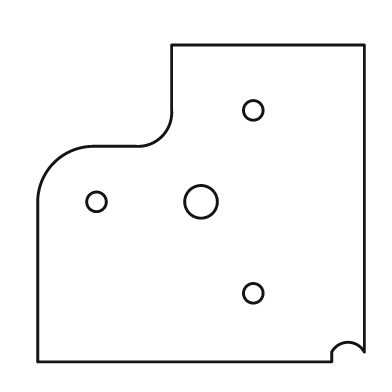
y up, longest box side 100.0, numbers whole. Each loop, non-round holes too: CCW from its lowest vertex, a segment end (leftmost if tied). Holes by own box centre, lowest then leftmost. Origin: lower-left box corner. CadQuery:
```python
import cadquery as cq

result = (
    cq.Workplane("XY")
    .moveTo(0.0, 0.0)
    .lineTo(90.0, 0.0)
    .lineTo(90.0, 3.0)
    .threePointArc((95.0, 6.0), (100.0, 3.0))
    .lineTo(100.0, 97.0)
    .lineTo(41.0, 97.0)
    .lineTo(41.0, 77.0)
    .threePointArc((38.0, 69.0), (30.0, 66.0))
    .lineTo(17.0, 66.0)
    .threePointArc((5.0, 61.0), (0.0, 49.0))
    .close()
    .moveTo(66.0, 21.0)
    .circle(3.0)
    .moveTo(18.0, 49.0)
    .circle(3.0)
    .moveTo(50.0, 49.0)
    .circle(5.0)
    .moveTo(66.0, 77.0)
    .circle(3.0)
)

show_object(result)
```